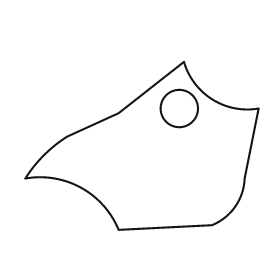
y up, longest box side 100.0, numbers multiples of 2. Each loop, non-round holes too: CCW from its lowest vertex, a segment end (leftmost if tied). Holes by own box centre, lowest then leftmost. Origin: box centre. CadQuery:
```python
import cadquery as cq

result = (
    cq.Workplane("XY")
    .moveTo(-10.0, -36.0)
    .lineTo(30.0, -34.0)
    .threePointArc((40.0, -26.0), (44.0, -14.0))
    .lineTo(50.0, 16.0)
    .threePointArc((30.0, 20.0), (18.0, 36.0))
    .lineTo(-10.0, 14.0)
    .lineTo(-32.0, 4.0)
    .threePointArc((-42.0, -4.0), (-50.0, -14.0))
    .threePointArc((-26.0, -18.0), (-10.0, -36.0))
    .close()
    .moveTo(16.0, 16.0)
    .circle(8.0)
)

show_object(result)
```